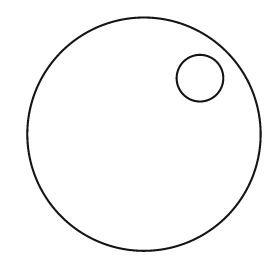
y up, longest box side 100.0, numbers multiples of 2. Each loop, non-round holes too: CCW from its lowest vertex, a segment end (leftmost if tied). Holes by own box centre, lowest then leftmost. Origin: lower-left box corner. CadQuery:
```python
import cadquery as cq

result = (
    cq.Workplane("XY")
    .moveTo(50.0, 50.0)
    .circle(50.0)
    .moveTo(74.0, 74.0)
    .circle(10.0)
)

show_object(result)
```